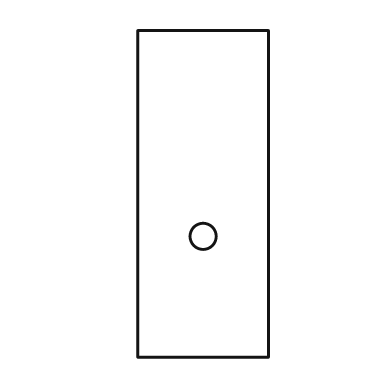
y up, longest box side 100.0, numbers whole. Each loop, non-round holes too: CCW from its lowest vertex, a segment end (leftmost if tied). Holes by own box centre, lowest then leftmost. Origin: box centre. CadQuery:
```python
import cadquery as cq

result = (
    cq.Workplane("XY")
    .moveTo(-20.0, -50.0)
    .lineTo(20.0, -50.0)
    .lineTo(20.0, 50.0)
    .lineTo(-20.0, 50.0)
    .close()
    .moveTo(0.0, -13.0)
    .circle(4.0)
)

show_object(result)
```